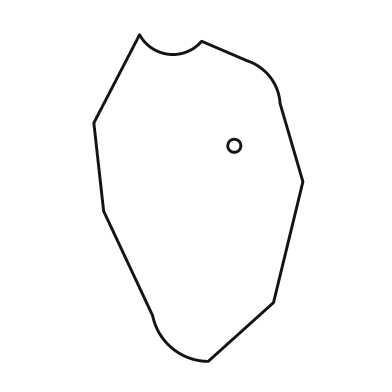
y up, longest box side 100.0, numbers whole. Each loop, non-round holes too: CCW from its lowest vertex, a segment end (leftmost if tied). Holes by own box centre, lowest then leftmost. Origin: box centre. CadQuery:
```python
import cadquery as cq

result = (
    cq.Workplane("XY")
    .moveTo(3.0, -50.0)
    .lineTo(23.0, -32.0)
    .lineTo(32.0, 5.0)
    .lineTo(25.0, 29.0)
    .threePointArc((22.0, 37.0), (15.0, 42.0))
    .lineTo(1.0, 48.0)
    .threePointArc((-9.0, 44.0), (-18.0, 50.0))
    .lineTo(-32.0, 23.0)
    .lineTo(-29.0, -4.0)
    .lineTo(-14.0, -36.0)
    .threePointArc((-8.0, -46.0), (3.0, -50.0))
    .close()
    .moveTo(11.0, 16.0)
    .circle(2.0)
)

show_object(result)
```